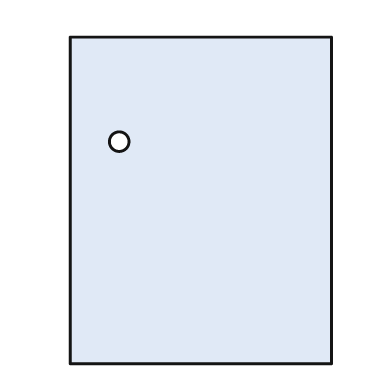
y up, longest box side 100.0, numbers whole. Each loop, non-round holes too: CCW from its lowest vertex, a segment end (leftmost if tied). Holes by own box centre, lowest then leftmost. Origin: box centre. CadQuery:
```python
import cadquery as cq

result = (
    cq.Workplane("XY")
    .moveTo(-40.0, -50.0)
    .lineTo(40.0, -50.0)
    .lineTo(40.0, 50.0)
    .lineTo(-40.0, 50.0)
    .close()
    .moveTo(-25.0, 18.0)
    .circle(3.0)
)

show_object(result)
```